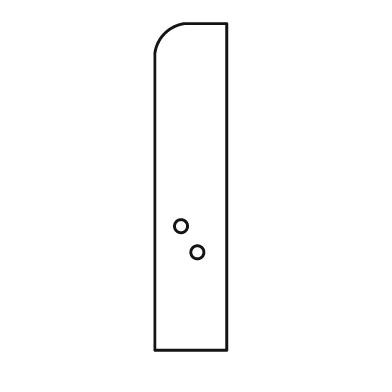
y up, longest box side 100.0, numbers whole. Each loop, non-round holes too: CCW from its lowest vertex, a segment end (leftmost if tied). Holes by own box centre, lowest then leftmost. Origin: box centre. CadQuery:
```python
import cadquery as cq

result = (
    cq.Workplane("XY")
    .moveTo(-11.0, -50.0)
    .lineTo(11.0, -50.0)
    .lineTo(11.0, 50.0)
    .lineTo(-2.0, 50.0)
    .threePointArc((-8.0, 47.0), (-11.0, 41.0))
    .close()
    .moveTo(2.0, -20.0)
    .circle(2.0)
    .moveTo(-3.0, -12.0)
    .circle(2.0)
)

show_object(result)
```